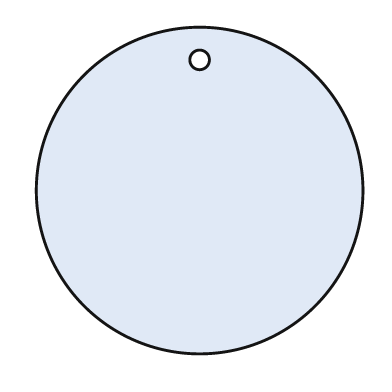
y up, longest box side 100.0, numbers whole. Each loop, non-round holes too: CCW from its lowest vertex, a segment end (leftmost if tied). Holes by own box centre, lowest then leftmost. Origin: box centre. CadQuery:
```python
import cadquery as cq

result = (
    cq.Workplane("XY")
    .moveTo(0.0, 0.0)
    .circle(50.0)
    .moveTo(0.0, 40.0)
    .circle(3.0)
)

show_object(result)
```